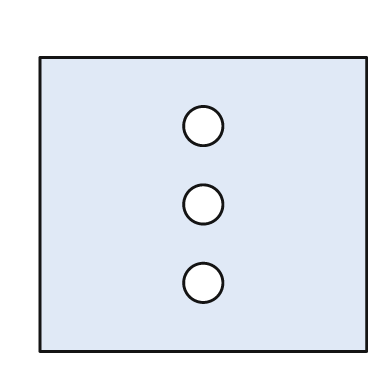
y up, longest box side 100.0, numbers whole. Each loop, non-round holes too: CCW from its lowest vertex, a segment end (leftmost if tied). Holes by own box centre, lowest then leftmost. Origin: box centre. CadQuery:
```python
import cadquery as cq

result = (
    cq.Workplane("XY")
    .moveTo(-50.0, -45.0)
    .lineTo(50.0, -45.0)
    .lineTo(50.0, 45.0)
    .lineTo(-50.0, 45.0)
    .close()
    .moveTo(0.0, -24.0)
    .circle(6.0)
    .moveTo(0.0, 0.0)
    .circle(6.0)
    .moveTo(0.0, 24.0)
    .circle(6.0)
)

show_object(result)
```